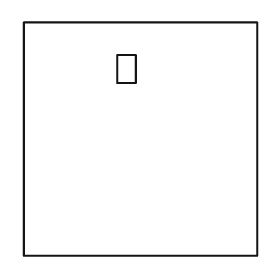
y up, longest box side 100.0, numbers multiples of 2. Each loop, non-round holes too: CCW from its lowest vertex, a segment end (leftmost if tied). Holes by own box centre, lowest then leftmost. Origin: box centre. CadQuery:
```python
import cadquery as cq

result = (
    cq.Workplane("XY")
    .moveTo(-50.0, -50.0)
    .lineTo(50.0, -50.0)
    .lineTo(50.0, 50.0)
    .lineTo(-50.0, 50.0)
    .close()
    .moveTo(-10.0, 24.0)
    .lineTo(-2.0, 24.0)
    .lineTo(-2.0, 36.0)
    .lineTo(-10.0, 36.0)
    .close()
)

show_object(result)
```